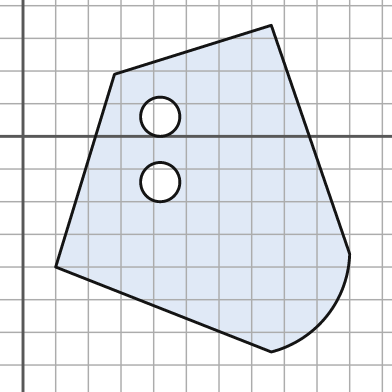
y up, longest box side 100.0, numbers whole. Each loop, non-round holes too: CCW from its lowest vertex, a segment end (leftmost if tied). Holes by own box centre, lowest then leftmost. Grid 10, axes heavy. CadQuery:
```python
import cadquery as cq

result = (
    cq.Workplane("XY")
    .moveTo(76.0, -66.0)
    .threePointArc((93.0, -55.0), (100.0, -36.0))
    .lineTo(76.0, 34.0)
    .lineTo(28.0, 19.0)
    .lineTo(10.0, -40.0)
    .close()
    .moveTo(42.0, -14.0)
    .circle(6.0)
    .moveTo(42.0, 6.0)
    .circle(6.0)
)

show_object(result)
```